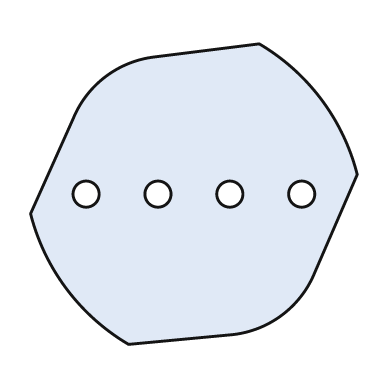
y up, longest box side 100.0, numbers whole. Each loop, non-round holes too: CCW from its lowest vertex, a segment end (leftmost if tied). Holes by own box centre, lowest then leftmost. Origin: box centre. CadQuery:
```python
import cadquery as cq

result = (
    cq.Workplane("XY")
    .moveTo(-20.0, -46.0)
    .lineTo(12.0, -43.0)
    .threePointArc((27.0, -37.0), (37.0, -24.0))
    .lineTo(50.0, 6.0)
    .threePointArc((39.0, 29.0), (20.0, 46.0))
    .lineTo(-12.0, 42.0)
    .threePointArc((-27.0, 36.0), (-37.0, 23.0))
    .lineTo(-50.0, -6.0)
    .threePointArc((-39.0, -29.0), (-20.0, -46.0))
    .close()
    .moveTo(-33.0, 0.0)
    .circle(4.0)
    .moveTo(-11.0, 0.0)
    .circle(4.0)
    .moveTo(11.0, 0.0)
    .circle(4.0)
    .moveTo(33.0, 0.0)
    .circle(4.0)
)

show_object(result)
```